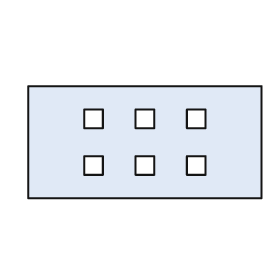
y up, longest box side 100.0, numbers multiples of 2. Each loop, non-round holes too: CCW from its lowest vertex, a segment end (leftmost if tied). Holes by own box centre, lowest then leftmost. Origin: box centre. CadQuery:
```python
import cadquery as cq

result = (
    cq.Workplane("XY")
    .moveTo(-50.0, -24.0)
    .lineTo(50.0, -24.0)
    .lineTo(50.0, 24.0)
    .lineTo(-50.0, 24.0)
    .close()
    .moveTo(-26.0, -14.0)
    .lineTo(-18.0, -14.0)
    .lineTo(-18.0, -6.0)
    .lineTo(-26.0, -6.0)
    .close()
    .moveTo(-4.0, -14.0)
    .lineTo(4.0, -14.0)
    .lineTo(4.0, -6.0)
    .lineTo(-4.0, -6.0)
    .close()
    .moveTo(18.0, -14.0)
    .lineTo(26.0, -14.0)
    .lineTo(26.0, -6.0)
    .lineTo(18.0, -6.0)
    .close()
    .moveTo(-26.0, 6.0)
    .lineTo(-18.0, 6.0)
    .lineTo(-18.0, 14.0)
    .lineTo(-26.0, 14.0)
    .close()
    .moveTo(-4.0, 6.0)
    .lineTo(4.0, 6.0)
    .lineTo(4.0, 14.0)
    .lineTo(-4.0, 14.0)
    .close()
    .moveTo(18.0, 6.0)
    .lineTo(26.0, 6.0)
    .lineTo(26.0, 14.0)
    .lineTo(18.0, 14.0)
    .close()
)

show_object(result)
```